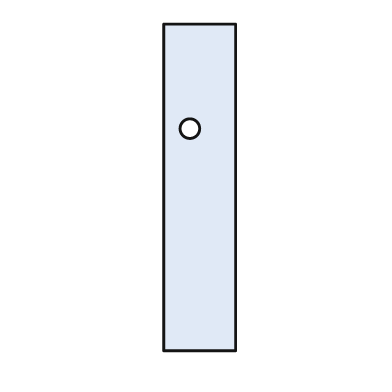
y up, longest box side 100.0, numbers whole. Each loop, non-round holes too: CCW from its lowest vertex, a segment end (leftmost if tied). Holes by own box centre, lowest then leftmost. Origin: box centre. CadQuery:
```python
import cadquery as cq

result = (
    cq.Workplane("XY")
    .moveTo(-11.0, -50.0)
    .lineTo(11.0, -50.0)
    .lineTo(11.0, 50.0)
    .lineTo(-11.0, 50.0)
    .close()
    .moveTo(-3.0, 18.0)
    .circle(3.0)
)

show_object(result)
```